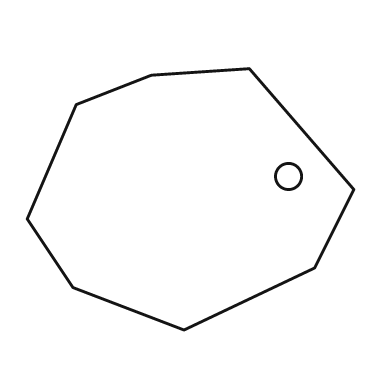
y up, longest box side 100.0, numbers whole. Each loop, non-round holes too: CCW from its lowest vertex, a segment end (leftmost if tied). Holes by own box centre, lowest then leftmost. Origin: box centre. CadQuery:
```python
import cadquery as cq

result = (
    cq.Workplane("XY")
    .moveTo(-2.0, -40.0)
    .lineTo(38.0, -21.0)
    .lineTo(50.0, 3.0)
    .lineTo(18.0, 40.0)
    .lineTo(-12.0, 38.0)
    .lineTo(-35.0, 29.0)
    .lineTo(-50.0, -6.0)
    .lineTo(-36.0, -27.0)
    .close()
    .moveTo(30.0, 7.0)
    .circle(4.0)
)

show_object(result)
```